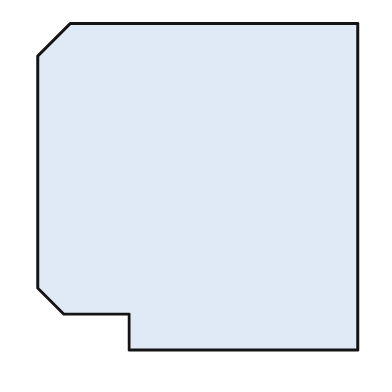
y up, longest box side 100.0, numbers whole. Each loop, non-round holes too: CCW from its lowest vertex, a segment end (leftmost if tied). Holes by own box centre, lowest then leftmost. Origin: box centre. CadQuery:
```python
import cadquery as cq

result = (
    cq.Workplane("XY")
    .moveTo(-21.0, -50.0)
    .lineTo(49.0, -50.0)
    .lineTo(49.0, 50.0)
    .lineTo(-39.0, 50.0)
    .lineTo(-49.0, 40.0)
    .lineTo(-49.0, -31.0)
    .lineTo(-41.0, -39.0)
    .lineTo(-21.0, -39.0)
    .close()
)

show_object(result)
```